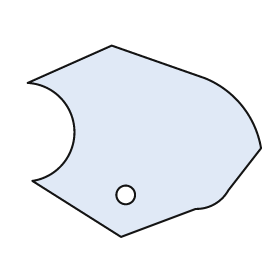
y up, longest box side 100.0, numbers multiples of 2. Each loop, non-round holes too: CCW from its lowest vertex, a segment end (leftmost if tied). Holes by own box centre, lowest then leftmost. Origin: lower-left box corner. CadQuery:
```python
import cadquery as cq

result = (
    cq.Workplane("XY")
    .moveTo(40.0, 0.0)
    .lineTo(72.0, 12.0)
    .threePointArc((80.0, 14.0), (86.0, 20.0))
    .lineTo(100.0, 38.0)
    .threePointArc((92.0, 56.0), (76.0, 68.0))
    .lineTo(36.0, 82.0)
    .lineTo(0.0, 66.0)
    .threePointArc((20.0, 46.0), (2.0, 24.0))
    .close()
    .moveTo(42.0, 18.0)
    .circle(4.0)
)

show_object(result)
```